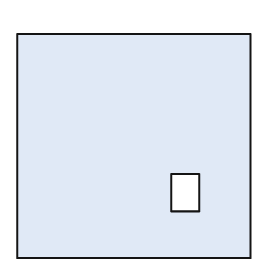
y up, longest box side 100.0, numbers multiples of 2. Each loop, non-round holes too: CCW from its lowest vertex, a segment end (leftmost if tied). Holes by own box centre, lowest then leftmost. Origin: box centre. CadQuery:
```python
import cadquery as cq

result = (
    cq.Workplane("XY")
    .moveTo(-50.0, -48.0)
    .lineTo(50.0, -48.0)
    .lineTo(50.0, 48.0)
    .lineTo(-50.0, 48.0)
    .close()
    .moveTo(16.0, -28.0)
    .lineTo(28.0, -28.0)
    .lineTo(28.0, -12.0)
    .lineTo(16.0, -12.0)
    .close()
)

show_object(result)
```